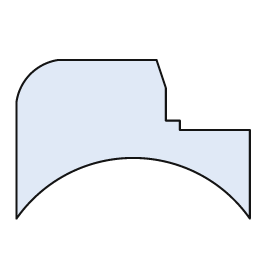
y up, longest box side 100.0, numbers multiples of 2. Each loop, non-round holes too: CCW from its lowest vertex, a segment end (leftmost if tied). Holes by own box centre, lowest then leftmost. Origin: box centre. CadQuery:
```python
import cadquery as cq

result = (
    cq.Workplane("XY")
    .moveTo(-50.0, -34.0)
    .threePointArc((0.0, -8.0), (50.0, -34.0))
    .lineTo(50.0, 4.0)
    .lineTo(20.0, 4.0)
    .lineTo(20.0, 8.0)
    .lineTo(14.0, 8.0)
    .lineTo(14.0, 22.0)
    .lineTo(10.0, 34.0)
    .lineTo(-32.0, 34.0)
    .threePointArc((-44.0, 28.0), (-50.0, 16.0))
    .close()
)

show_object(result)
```